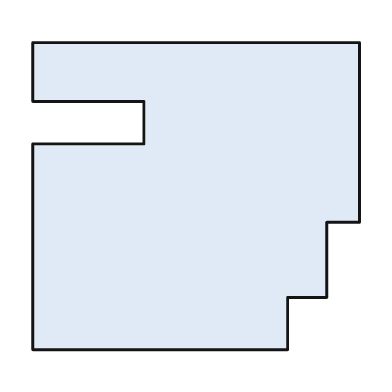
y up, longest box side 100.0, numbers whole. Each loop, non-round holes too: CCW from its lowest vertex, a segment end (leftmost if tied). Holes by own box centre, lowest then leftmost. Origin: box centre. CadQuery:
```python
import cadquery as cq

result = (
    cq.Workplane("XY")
    .moveTo(-50.0, -47.0)
    .lineTo(28.0, -47.0)
    .lineTo(28.0, -31.0)
    .lineTo(40.0, -31.0)
    .lineTo(40.0, -8.0)
    .lineTo(50.0, -8.0)
    .lineTo(50.0, 47.0)
    .lineTo(-50.0, 47.0)
    .lineTo(-50.0, 29.0)
    .lineTo(-16.0, 29.0)
    .lineTo(-16.0, 16.0)
    .lineTo(-50.0, 16.0)
    .close()
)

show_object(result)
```